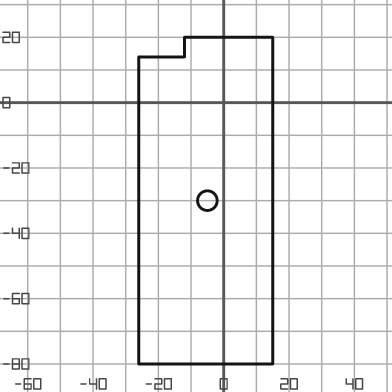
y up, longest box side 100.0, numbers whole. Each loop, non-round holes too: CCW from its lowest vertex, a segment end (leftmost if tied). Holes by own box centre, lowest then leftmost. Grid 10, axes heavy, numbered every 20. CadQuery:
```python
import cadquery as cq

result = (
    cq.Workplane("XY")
    .moveTo(-26.0, -80.0)
    .lineTo(15.0, -80.0)
    .lineTo(15.0, 20.0)
    .lineTo(-12.0, 20.0)
    .lineTo(-12.0, 14.0)
    .lineTo(-26.0, 14.0)
    .close()
    .moveTo(-5.0, -30.0)
    .circle(3.0)
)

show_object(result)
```